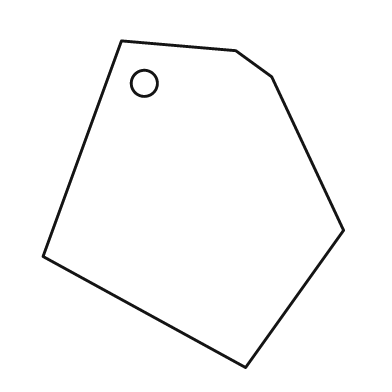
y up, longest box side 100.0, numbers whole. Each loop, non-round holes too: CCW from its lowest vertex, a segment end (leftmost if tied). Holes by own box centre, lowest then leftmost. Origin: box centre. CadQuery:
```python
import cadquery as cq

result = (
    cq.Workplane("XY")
    .moveTo(16.0, -50.0)
    .lineTo(46.0, -8.0)
    .lineTo(24.0, 39.0)
    .lineTo(13.0, 47.0)
    .lineTo(-22.0, 50.0)
    .lineTo(-46.0, -16.0)
    .close()
    .moveTo(-15.0, 37.0)
    .circle(4.0)
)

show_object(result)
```